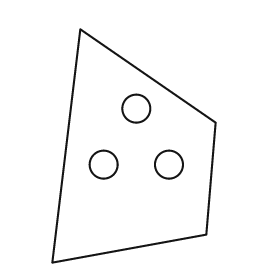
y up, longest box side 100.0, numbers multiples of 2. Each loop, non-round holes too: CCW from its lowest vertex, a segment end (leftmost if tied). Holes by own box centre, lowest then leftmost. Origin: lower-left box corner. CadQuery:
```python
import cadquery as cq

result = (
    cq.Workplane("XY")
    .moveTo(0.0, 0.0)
    .lineTo(66.0, 12.0)
    .lineTo(70.0, 60.0)
    .lineTo(12.0, 100.0)
    .close()
    .moveTo(22.0, 42.0)
    .circle(6.0)
    .moveTo(50.0, 42.0)
    .circle(6.0)
    .moveTo(36.0, 66.0)
    .circle(6.0)
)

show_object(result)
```